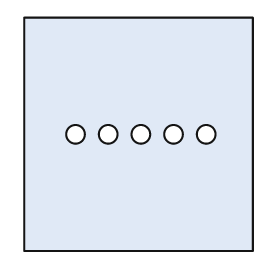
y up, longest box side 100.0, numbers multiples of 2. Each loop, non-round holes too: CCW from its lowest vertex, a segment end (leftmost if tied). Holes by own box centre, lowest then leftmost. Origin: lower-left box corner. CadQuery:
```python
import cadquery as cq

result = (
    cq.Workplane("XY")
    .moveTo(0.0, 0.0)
    .lineTo(98.0, 0.0)
    .lineTo(98.0, 100.0)
    .lineTo(0.0, 100.0)
    .close()
    .moveTo(22.0, 50.0)
    .circle(4.0)
    .moveTo(36.0, 50.0)
    .circle(4.0)
    .moveTo(50.0, 50.0)
    .circle(4.0)
    .moveTo(64.0, 50.0)
    .circle(4.0)
    .moveTo(78.0, 50.0)
    .circle(4.0)
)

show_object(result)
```